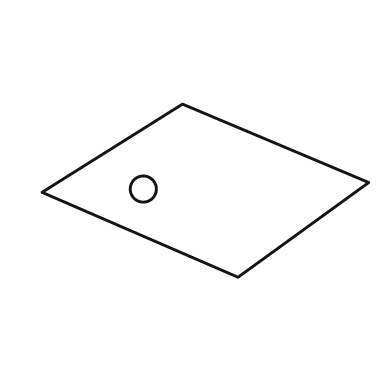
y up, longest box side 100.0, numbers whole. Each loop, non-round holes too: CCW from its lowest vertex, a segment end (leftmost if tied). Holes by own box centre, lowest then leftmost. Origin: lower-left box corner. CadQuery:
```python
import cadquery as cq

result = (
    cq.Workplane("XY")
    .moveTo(60.0, 0.0)
    .lineTo(100.0, 29.0)
    .lineTo(43.0, 53.0)
    .lineTo(0.0, 26.0)
    .close()
    .moveTo(31.0, 27.0)
    .circle(4.0)
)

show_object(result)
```